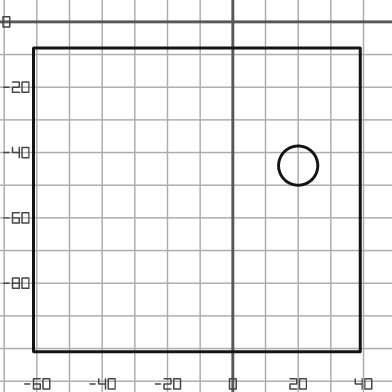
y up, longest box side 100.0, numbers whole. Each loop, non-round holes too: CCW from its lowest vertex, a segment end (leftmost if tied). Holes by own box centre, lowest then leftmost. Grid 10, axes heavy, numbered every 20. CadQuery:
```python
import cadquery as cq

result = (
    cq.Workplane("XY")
    .moveTo(-61.0, -101.0)
    .lineTo(39.0, -101.0)
    .lineTo(39.0, -8.0)
    .lineTo(-61.0, -8.0)
    .close()
    .moveTo(20.0, -44.0)
    .circle(6.0)
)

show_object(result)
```